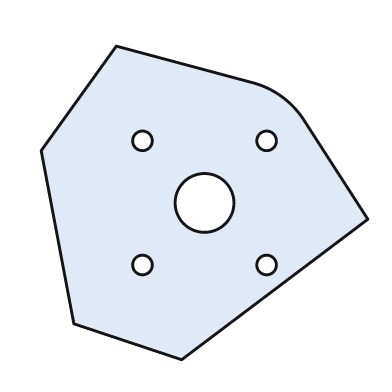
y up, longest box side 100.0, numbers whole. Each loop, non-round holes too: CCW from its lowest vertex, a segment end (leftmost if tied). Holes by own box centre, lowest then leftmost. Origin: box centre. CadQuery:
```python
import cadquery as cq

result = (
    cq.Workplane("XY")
    .moveTo(-7.0, -48.0)
    .lineTo(50.0, -5.0)
    .lineTo(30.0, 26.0)
    .threePointArc((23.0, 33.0), (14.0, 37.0))
    .lineTo(-27.0, 48.0)
    .lineTo(-50.0, 16.0)
    .lineTo(-40.0, -37.0)
    .close()
    .moveTo(-19.0, -19.0)
    .circle(3.0)
    .moveTo(19.0, -19.0)
    .circle(3.0)
    .moveTo(0.0, 0.0)
    .circle(9.0)
    .moveTo(-19.0, 19.0)
    .circle(3.0)
    .moveTo(19.0, 19.0)
    .circle(3.0)
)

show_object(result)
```